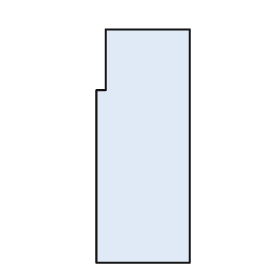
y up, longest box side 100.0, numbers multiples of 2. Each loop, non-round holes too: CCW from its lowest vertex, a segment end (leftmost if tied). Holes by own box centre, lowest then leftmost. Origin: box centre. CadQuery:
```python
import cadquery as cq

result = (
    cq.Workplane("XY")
    .moveTo(-20.0, -50.0)
    .lineTo(20.0, -50.0)
    .lineTo(20.0, 50.0)
    .lineTo(-16.0, 50.0)
    .lineTo(-16.0, 24.0)
    .lineTo(-20.0, 24.0)
    .close()
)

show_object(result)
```